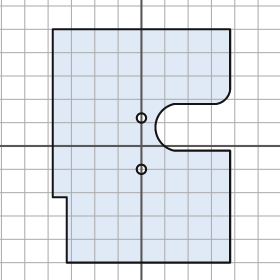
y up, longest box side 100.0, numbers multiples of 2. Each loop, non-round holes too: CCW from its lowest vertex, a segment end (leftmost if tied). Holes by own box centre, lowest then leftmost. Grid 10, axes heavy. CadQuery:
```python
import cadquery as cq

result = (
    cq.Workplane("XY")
    .moveTo(-32.0, -50.0)
    .lineTo(38.0, -50.0)
    .lineTo(38.0, -2.0)
    .lineTo(14.0, -2.0)
    .threePointArc((6.0, 8.0), (14.0, 18.0))
    .lineTo(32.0, 18.0)
    .threePointArc((36.0, 20.0), (38.0, 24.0))
    .lineTo(38.0, 50.0)
    .lineTo(-38.0, 50.0)
    .lineTo(-38.0, -22.0)
    .lineTo(-32.0, -22.0)
    .close()
    .moveTo(0.0, -10.0)
    .circle(2.0)
    .moveTo(0.0, 12.0)
    .circle(2.0)
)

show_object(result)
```